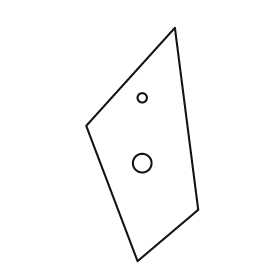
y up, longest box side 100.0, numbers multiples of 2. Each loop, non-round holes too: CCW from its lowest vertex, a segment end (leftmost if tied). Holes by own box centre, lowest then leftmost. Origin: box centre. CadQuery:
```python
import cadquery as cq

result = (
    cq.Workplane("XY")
    .moveTo(-2.0, -50.0)
    .lineTo(24.0, -28.0)
    .lineTo(14.0, 50.0)
    .lineTo(-24.0, 8.0)
    .close()
    .moveTo(0.0, -8.0)
    .circle(4.0)
    .moveTo(0.0, 20.0)
    .circle(2.0)
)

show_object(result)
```